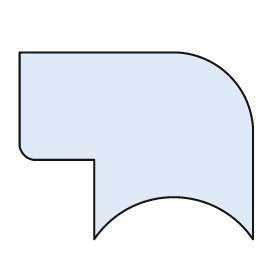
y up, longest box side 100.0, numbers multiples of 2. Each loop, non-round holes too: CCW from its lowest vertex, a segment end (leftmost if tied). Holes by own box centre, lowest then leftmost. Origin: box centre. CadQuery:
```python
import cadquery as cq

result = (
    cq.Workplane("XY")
    .moveTo(-18.0, -40.0)
    .threePointArc((16.0, -22.0), (50.0, -40.0))
    .lineTo(50.0, 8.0)
    .threePointArc((40.0, 30.0), (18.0, 40.0))
    .lineTo(-50.0, 40.0)
    .lineTo(-50.0, 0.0)
    .threePointArc((-48.0, -4.0), (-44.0, -6.0))
    .lineTo(-18.0, -6.0)
    .close()
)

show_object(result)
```